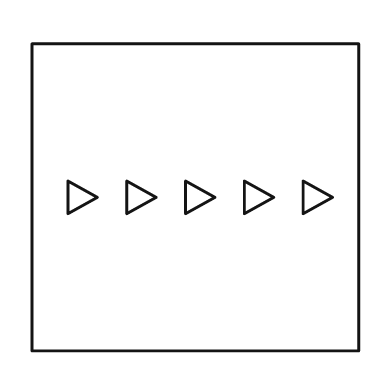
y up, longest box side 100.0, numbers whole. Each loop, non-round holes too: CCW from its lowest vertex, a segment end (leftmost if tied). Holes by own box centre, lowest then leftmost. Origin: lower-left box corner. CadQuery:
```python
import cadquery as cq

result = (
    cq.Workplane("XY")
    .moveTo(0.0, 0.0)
    .lineTo(100.0, 0.0)
    .lineTo(100.0, 94.0)
    .lineTo(0.0, 94.0)
    .close()
    .moveTo(11.0, 42.0)
    .lineTo(20.0, 47.0)
    .lineTo(11.0, 52.0)
    .close()
    .moveTo(29.0, 42.0)
    .lineTo(38.0, 47.0)
    .lineTo(29.0, 52.0)
    .close()
    .moveTo(47.0, 42.0)
    .lineTo(56.0, 47.0)
    .lineTo(47.0, 52.0)
    .close()
    .moveTo(65.0, 42.0)
    .lineTo(74.0, 47.0)
    .lineTo(65.0, 52.0)
    .close()
    .moveTo(83.0, 42.0)
    .lineTo(92.0, 47.0)
    .lineTo(83.0, 52.0)
    .close()
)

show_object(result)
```